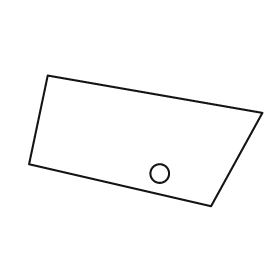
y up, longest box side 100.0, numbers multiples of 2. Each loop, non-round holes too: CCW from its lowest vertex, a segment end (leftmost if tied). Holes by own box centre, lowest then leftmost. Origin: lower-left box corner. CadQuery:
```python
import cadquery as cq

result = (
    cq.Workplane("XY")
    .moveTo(78.0, 0.0)
    .lineTo(100.0, 40.0)
    .lineTo(8.0, 56.0)
    .lineTo(0.0, 18.0)
    .close()
    .moveTo(56.0, 14.0)
    .circle(4.0)
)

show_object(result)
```